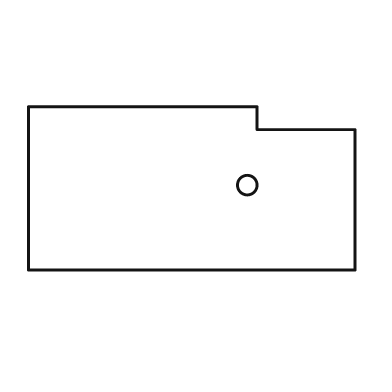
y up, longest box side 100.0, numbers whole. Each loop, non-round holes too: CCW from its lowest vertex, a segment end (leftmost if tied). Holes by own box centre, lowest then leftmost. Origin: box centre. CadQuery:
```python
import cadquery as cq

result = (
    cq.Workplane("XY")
    .moveTo(-50.0, -25.0)
    .lineTo(50.0, -25.0)
    .lineTo(50.0, 18.0)
    .lineTo(20.0, 18.0)
    .lineTo(20.0, 25.0)
    .lineTo(-50.0, 25.0)
    .close()
    .moveTo(17.0, 1.0)
    .circle(3.0)
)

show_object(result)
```